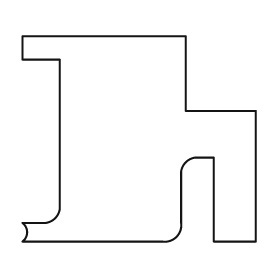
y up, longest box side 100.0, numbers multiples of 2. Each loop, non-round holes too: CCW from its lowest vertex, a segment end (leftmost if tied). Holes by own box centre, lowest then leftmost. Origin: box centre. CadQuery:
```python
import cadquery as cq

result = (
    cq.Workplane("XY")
    .moveTo(-50.0, -44.0)
    .lineTo(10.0, -44.0)
    .threePointArc((16.0, -42.0), (18.0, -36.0))
    .lineTo(18.0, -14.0)
    .threePointArc((20.0, -10.0), (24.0, -8.0))
    .lineTo(32.0, -8.0)
    .lineTo(32.0, -44.0)
    .lineTo(50.0, -44.0)
    .lineTo(50.0, 12.0)
    .lineTo(20.0, 12.0)
    .lineTo(20.0, 44.0)
    .lineTo(-50.0, 44.0)
    .lineTo(-50.0, 34.0)
    .lineTo(-34.0, 34.0)
    .lineTo(-34.0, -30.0)
    .threePointArc((-36.0, -34.0), (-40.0, -36.0))
    .lineTo(-50.0, -36.0)
    .threePointArc((-48.0, -40.0), (-50.0, -44.0))
    .close()
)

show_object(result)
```